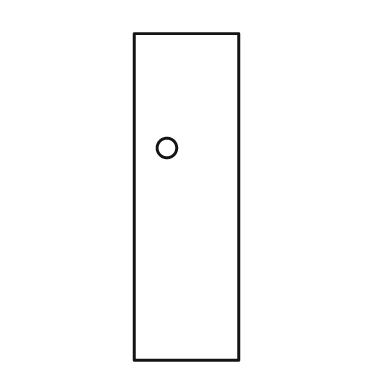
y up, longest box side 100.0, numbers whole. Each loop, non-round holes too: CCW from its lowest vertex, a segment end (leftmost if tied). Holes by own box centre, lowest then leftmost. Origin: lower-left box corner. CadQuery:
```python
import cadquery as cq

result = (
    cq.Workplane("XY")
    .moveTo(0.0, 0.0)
    .lineTo(32.0, 0.0)
    .lineTo(32.0, 100.0)
    .lineTo(0.0, 100.0)
    .close()
    .moveTo(10.0, 65.0)
    .circle(3.0)
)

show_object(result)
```